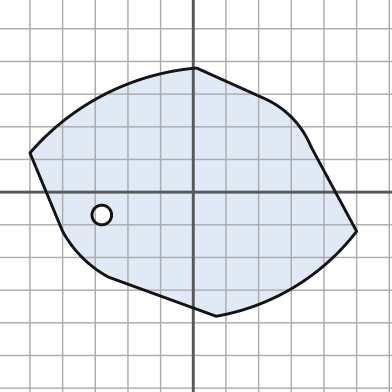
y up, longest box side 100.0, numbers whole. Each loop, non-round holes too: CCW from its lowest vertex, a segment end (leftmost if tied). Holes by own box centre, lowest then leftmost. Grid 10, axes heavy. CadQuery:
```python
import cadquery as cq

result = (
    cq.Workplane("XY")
    .moveTo(7.0, -38.0)
    .threePointArc((31.0, -29.0), (50.0, -12.0))
    .lineTo(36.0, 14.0)
    .threePointArc((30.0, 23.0), (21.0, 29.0))
    .lineTo(1.0, 38.0)
    .threePointArc((-27.0, 30.0), (-50.0, 12.0))
    .lineTo(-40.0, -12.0)
    .threePointArc((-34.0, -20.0), (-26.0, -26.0))
    .close()
    .moveTo(-28.0, -7.0)
    .circle(3.0)
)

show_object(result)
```